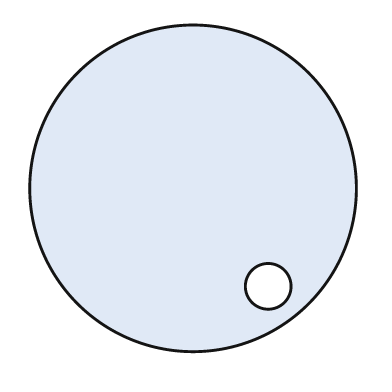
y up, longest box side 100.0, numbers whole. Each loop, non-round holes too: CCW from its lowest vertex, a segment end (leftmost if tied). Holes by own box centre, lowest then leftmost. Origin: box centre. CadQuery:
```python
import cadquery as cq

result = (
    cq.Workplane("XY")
    .moveTo(0.0, 0.0)
    .circle(50.0)
    .moveTo(23.0, -30.0)
    .circle(7.0)
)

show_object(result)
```